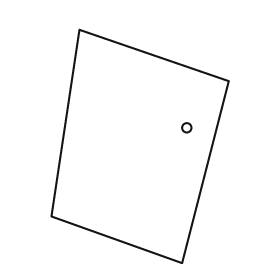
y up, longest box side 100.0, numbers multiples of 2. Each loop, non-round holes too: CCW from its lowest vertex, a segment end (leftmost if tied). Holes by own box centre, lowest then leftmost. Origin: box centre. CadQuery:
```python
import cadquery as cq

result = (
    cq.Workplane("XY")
    .moveTo(18.0, -50.0)
    .lineTo(38.0, 28.0)
    .lineTo(-26.0, 50.0)
    .lineTo(-38.0, -30.0)
    .close()
    .moveTo(20.0, 8.0)
    .circle(2.0)
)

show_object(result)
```